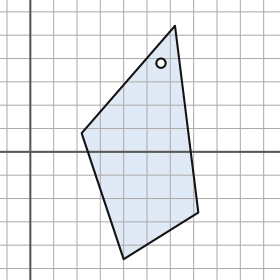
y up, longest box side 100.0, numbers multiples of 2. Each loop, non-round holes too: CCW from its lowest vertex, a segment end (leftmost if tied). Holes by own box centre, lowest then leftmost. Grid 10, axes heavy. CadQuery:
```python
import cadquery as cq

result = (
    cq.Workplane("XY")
    .moveTo(40.0, -46.0)
    .lineTo(72.0, -26.0)
    .lineTo(62.0, 54.0)
    .lineTo(22.0, 8.0)
    .close()
    .moveTo(56.0, 38.0)
    .circle(2.0)
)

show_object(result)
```